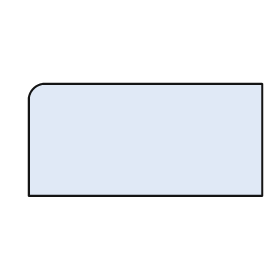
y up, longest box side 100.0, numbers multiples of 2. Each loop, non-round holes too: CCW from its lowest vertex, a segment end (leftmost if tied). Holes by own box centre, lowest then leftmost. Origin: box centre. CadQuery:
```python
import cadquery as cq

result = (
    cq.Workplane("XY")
    .moveTo(-50.0, -24.0)
    .lineTo(50.0, -24.0)
    .lineTo(50.0, 24.0)
    .lineTo(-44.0, 24.0)
    .threePointArc((-48.0, 22.0), (-50.0, 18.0))
    .close()
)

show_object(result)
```